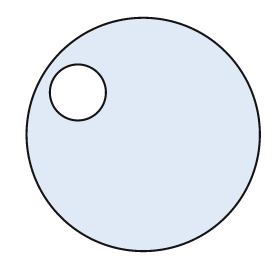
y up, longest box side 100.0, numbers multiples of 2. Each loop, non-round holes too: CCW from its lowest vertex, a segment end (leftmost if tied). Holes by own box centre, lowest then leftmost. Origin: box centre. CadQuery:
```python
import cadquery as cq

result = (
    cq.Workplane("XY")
    .moveTo(0.0, 0.0)
    .circle(50.0)
    .moveTo(-28.0, 18.0)
    .circle(12.0)
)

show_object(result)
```